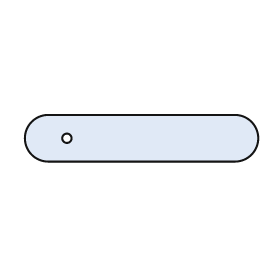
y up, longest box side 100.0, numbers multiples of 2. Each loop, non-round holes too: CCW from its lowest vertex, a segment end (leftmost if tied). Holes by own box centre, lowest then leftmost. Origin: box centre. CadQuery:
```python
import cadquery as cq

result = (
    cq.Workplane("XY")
    .moveTo(-40.0, -10.0)
    .lineTo(40.0, -10.0)
    .threePointArc((50.0, 0.0), (40.0, 10.0))
    .lineTo(-40.0, 10.0)
    .threePointArc((-50.0, 0.0), (-40.0, -10.0))
    .close()
    .moveTo(-32.0, 0.0)
    .circle(2.0)
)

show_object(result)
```